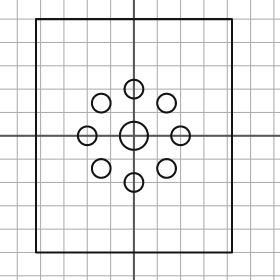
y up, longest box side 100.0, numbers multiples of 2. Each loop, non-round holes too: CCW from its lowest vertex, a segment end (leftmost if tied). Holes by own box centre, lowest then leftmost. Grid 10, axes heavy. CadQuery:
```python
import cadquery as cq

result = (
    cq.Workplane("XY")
    .moveTo(-42.0, -50.0)
    .lineTo(42.0, -50.0)
    .lineTo(42.0, 50.0)
    .lineTo(-42.0, 50.0)
    .close()
    .moveTo(0.0, -20.0)
    .circle(4.0)
    .moveTo(-14.0, -14.0)
    .circle(4.0)
    .moveTo(14.0, -14.0)
    .circle(4.0)
    .moveTo(-20.0, 0.0)
    .circle(4.0)
    .moveTo(0.0, 0.0)
    .circle(6.0)
    .moveTo(20.0, 0.0)
    .circle(4.0)
    .moveTo(-14.0, 14.0)
    .circle(4.0)
    .moveTo(14.0, 14.0)
    .circle(4.0)
    .moveTo(0.0, 20.0)
    .circle(4.0)
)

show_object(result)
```